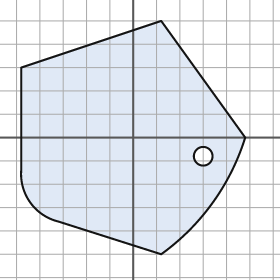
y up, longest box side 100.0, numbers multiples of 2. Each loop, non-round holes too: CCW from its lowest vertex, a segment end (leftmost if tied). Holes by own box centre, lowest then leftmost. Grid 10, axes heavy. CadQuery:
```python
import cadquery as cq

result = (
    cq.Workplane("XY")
    .moveTo(12.0, -50.0)
    .threePointArc((34.0, -28.0), (48.0, 0.0))
    .lineTo(12.0, 50.0)
    .lineTo(-48.0, 30.0)
    .lineTo(-48.0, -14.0)
    .threePointArc((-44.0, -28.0), (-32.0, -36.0))
    .close()
    .moveTo(30.0, -8.0)
    .circle(4.0)
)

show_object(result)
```